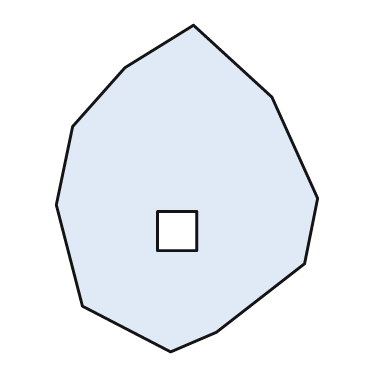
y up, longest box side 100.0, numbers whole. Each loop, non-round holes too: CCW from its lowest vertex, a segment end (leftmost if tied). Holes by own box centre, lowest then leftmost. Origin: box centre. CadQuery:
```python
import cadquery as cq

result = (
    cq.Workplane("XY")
    .moveTo(-5.0, -50.0)
    .lineTo(9.0, -44.0)
    .lineTo(36.0, -23.0)
    .lineTo(40.0, -3.0)
    .lineTo(26.0, 28.0)
    .lineTo(2.0, 50.0)
    .lineTo(-19.0, 37.0)
    .lineTo(-35.0, 19.0)
    .lineTo(-40.0, -5.0)
    .lineTo(-32.0, -36.0)
    .close()
    .moveTo(-9.0, -19.0)
    .lineTo(3.0, -19.0)
    .lineTo(3.0, -7.0)
    .lineTo(-9.0, -7.0)
    .close()
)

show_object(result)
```